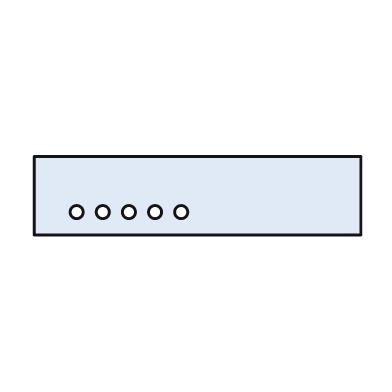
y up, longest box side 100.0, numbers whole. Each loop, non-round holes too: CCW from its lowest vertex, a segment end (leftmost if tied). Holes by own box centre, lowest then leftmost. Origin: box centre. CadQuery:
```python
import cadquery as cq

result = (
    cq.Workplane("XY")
    .moveTo(-50.0, -12.0)
    .lineTo(50.0, -12.0)
    .lineTo(50.0, 12.0)
    .lineTo(-50.0, 12.0)
    .close()
    .moveTo(-37.0, -5.0)
    .circle(2.0)
    .moveTo(-29.0, -5.0)
    .circle(2.0)
    .moveTo(-21.0, -5.0)
    .circle(2.0)
    .moveTo(-13.0, -5.0)
    .circle(2.0)
    .moveTo(-5.0, -5.0)
    .circle(2.0)
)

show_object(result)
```